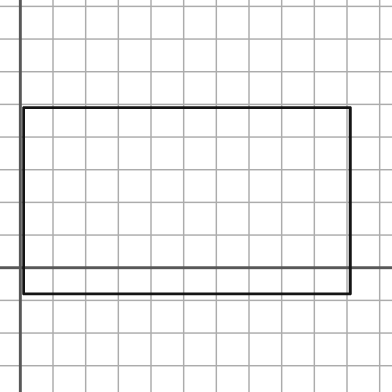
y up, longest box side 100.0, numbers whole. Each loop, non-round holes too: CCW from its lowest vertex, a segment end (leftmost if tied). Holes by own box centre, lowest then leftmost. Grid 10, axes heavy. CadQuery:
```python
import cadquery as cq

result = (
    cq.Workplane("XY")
    .moveTo(1.0, -8.0)
    .lineTo(101.0, -8.0)
    .lineTo(101.0, 49.0)
    .lineTo(1.0, 49.0)
    .close()
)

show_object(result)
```